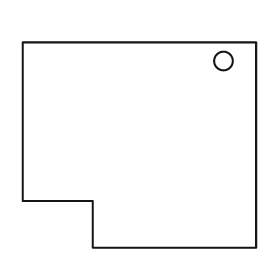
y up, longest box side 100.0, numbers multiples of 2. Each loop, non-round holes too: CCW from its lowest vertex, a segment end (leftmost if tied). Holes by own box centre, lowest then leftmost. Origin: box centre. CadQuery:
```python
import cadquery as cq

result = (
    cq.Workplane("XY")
    .moveTo(-20.0, -44.0)
    .lineTo(50.0, -44.0)
    .lineTo(50.0, 44.0)
    .lineTo(-50.0, 44.0)
    .lineTo(-50.0, -24.0)
    .lineTo(-20.0, -24.0)
    .close()
    .moveTo(36.0, 36.0)
    .circle(4.0)
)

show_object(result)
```